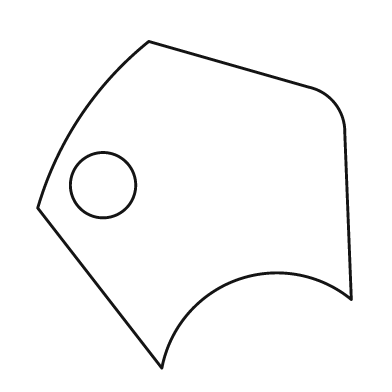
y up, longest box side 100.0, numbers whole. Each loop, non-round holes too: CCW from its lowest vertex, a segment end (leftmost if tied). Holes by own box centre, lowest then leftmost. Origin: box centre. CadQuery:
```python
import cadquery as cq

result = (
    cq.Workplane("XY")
    .moveTo(-10.0, -50.0)
    .threePointArc((13.0, -23.0), (48.0, -29.0))
    .lineTo(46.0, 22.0)
    .threePointArc((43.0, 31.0), (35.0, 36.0))
    .lineTo(-14.0, 50.0)
    .threePointArc((-35.0, 27.0), (-48.0, -1.0))
    .close()
    .moveTo(-28.0, 6.0)
    .circle(10.0)
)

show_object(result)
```